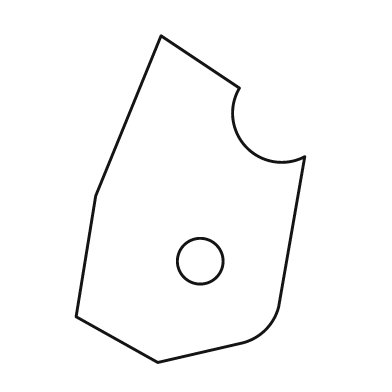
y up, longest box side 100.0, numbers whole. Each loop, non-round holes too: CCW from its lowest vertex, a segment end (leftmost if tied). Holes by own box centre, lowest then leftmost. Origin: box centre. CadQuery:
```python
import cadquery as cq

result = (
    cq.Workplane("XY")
    .moveTo(-10.0, -50.0)
    .lineTo(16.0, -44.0)
    .threePointArc((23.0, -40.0), (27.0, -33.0))
    .lineTo(35.0, 13.0)
    .threePointArc((17.0, 16.0), (15.0, 34.0))
    .lineTo(-9.0, 50.0)
    .lineTo(-29.0, 1.0)
    .lineTo(-35.0, -36.0)
    .close()
    .moveTo(3.0, -19.0)
    .circle(7.0)
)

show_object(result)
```